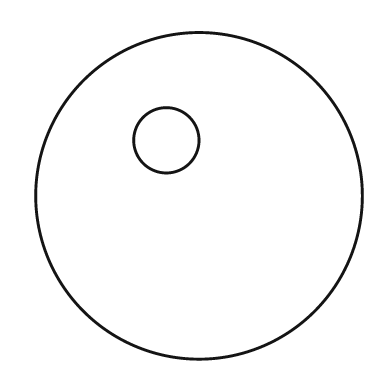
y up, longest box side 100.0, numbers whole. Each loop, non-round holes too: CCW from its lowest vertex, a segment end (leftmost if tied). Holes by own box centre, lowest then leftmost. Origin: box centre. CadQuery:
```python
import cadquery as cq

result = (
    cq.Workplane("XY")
    .moveTo(0.0, 0.0)
    .circle(50.0)
    .moveTo(-10.0, 17.0)
    .circle(10.0)
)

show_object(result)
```